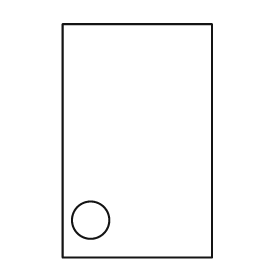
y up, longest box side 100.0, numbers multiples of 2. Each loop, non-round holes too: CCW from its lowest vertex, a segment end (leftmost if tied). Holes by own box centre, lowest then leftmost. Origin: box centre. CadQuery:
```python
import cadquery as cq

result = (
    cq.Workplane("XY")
    .moveTo(-32.0, -50.0)
    .lineTo(32.0, -50.0)
    .lineTo(32.0, 50.0)
    .lineTo(-32.0, 50.0)
    .close()
    .moveTo(-20.0, -34.0)
    .circle(8.0)
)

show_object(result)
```